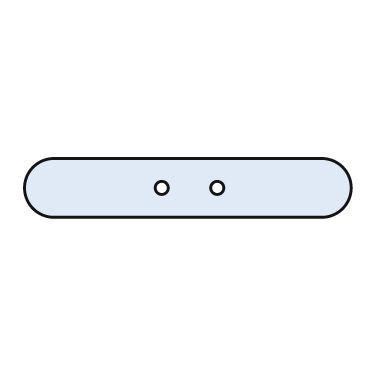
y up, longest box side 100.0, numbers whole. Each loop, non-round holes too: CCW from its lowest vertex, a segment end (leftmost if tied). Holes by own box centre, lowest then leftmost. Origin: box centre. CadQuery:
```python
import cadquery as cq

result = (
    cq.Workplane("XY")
    .moveTo(-41.0, -9.0)
    .lineTo(41.0, -9.0)
    .threePointArc((50.0, 0.0), (41.0, 9.0))
    .lineTo(-41.0, 9.0)
    .threePointArc((-50.0, 0.0), (-41.0, -9.0))
    .close()
    .moveTo(-8.0, 0.0)
    .circle(2.0)
    .moveTo(9.0, 0.0)
    .circle(2.0)
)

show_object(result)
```